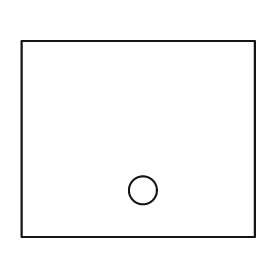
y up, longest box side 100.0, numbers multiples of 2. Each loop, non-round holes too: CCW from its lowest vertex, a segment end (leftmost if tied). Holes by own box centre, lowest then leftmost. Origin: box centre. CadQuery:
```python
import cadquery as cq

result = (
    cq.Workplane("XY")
    .moveTo(-50.0, -42.0)
    .lineTo(50.0, -42.0)
    .lineTo(50.0, 42.0)
    .lineTo(-50.0, 42.0)
    .close()
    .moveTo(2.0, -22.0)
    .circle(6.0)
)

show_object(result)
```